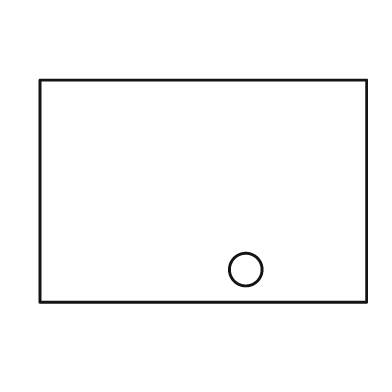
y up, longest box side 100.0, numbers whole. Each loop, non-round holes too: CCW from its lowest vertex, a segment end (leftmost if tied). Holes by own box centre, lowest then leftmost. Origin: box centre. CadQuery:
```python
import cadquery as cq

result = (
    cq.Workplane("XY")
    .moveTo(-50.0, -34.0)
    .lineTo(50.0, -34.0)
    .lineTo(50.0, 34.0)
    .lineTo(-50.0, 34.0)
    .close()
    .moveTo(13.0, -24.0)
    .circle(5.0)
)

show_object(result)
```